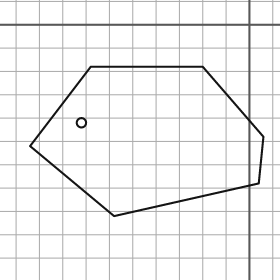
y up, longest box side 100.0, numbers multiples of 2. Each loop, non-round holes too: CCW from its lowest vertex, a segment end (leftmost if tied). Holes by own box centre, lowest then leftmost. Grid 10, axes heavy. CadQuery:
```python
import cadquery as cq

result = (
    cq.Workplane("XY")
    .moveTo(-58.0, -82.0)
    .lineTo(4.0, -68.0)
    .lineTo(6.0, -48.0)
    .lineTo(-20.0, -18.0)
    .lineTo(-68.0, -18.0)
    .lineTo(-94.0, -52.0)
    .close()
    .moveTo(-72.0, -42.0)
    .circle(2.0)
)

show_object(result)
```